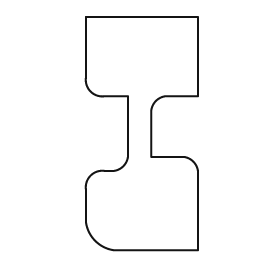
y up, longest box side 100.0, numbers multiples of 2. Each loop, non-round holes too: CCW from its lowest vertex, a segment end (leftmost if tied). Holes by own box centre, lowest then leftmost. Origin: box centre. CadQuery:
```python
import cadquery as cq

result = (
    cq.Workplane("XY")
    .moveTo(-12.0, -50.0)
    .lineTo(24.0, -50.0)
    .lineTo(24.0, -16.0)
    .threePointArc((22.0, -12.0), (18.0, -10.0))
    .lineTo(4.0, -10.0)
    .lineTo(4.0, 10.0)
    .threePointArc((6.0, 14.0), (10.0, 16.0))
    .lineTo(24.0, 16.0)
    .lineTo(24.0, 50.0)
    .lineTo(-24.0, 50.0)
    .lineTo(-24.0, 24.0)
    .threePointArc((-22.0, 18.0), (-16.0, 16.0))
    .lineTo(-6.0, 16.0)
    .lineTo(-6.0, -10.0)
    .threePointArc((-8.0, -14.0), (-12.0, -16.0))
    .lineTo(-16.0, -16.0)
    .threePointArc((-22.0, -18.0), (-24.0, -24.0))
    .lineTo(-24.0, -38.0)
    .threePointArc((-20.0, -46.0), (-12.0, -50.0))
    .close()
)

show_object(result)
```